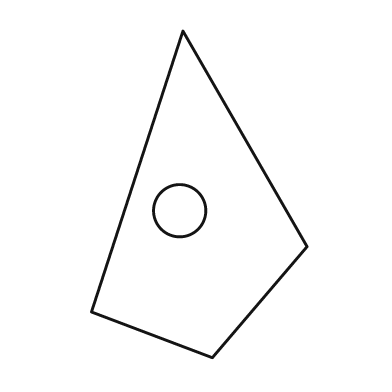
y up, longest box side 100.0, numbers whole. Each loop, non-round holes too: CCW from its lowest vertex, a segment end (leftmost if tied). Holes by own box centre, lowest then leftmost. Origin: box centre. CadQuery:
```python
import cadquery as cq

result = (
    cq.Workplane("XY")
    .moveTo(4.0, -50.0)
    .lineTo(33.0, -16.0)
    .lineTo(-5.0, 50.0)
    .lineTo(-33.0, -36.0)
    .close()
    .moveTo(-6.0, -5.0)
    .circle(8.0)
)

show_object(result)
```